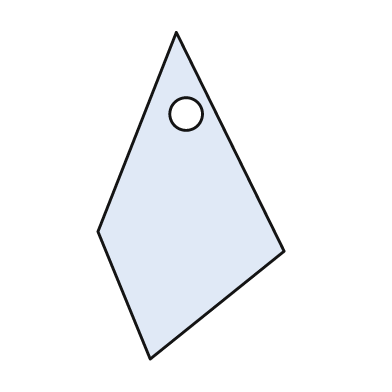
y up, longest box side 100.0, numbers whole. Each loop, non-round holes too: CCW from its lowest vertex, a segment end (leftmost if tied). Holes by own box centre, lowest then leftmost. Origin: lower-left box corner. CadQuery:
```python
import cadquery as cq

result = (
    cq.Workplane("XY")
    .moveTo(16.0, 0.0)
    .lineTo(57.0, 33.0)
    .lineTo(24.0, 100.0)
    .lineTo(0.0, 39.0)
    .close()
    .moveTo(27.0, 75.0)
    .circle(5.0)
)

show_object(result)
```